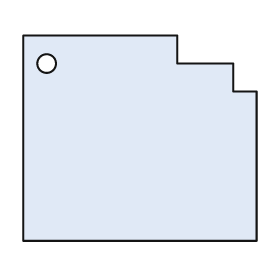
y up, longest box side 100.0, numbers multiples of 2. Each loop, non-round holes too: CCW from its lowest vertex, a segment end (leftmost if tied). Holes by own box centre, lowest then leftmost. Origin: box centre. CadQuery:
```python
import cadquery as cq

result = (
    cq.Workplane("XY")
    .moveTo(-50.0, -44.0)
    .lineTo(50.0, -44.0)
    .lineTo(50.0, 20.0)
    .lineTo(40.0, 20.0)
    .lineTo(40.0, 32.0)
    .lineTo(16.0, 32.0)
    .lineTo(16.0, 44.0)
    .lineTo(-50.0, 44.0)
    .close()
    .moveTo(-40.0, 32.0)
    .circle(4.0)
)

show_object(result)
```